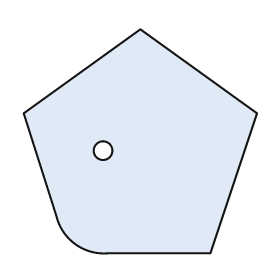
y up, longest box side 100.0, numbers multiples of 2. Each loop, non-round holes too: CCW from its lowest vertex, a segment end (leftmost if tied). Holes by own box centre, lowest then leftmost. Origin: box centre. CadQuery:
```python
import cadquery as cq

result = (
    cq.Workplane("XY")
    .moveTo(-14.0, -48.0)
    .lineTo(30.0, -48.0)
    .lineTo(50.0, 12.0)
    .lineTo(0.0, 48.0)
    .lineTo(-50.0, 12.0)
    .lineTo(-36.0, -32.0)
    .threePointArc((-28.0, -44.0), (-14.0, -48.0))
    .close()
    .moveTo(-16.0, -4.0)
    .circle(4.0)
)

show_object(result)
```